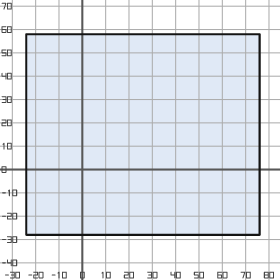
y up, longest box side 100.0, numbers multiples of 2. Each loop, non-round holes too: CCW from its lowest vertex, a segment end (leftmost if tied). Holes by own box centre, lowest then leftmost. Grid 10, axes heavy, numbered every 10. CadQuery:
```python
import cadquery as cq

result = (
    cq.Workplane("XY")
    .moveTo(-24.0, -28.0)
    .lineTo(76.0, -28.0)
    .lineTo(76.0, 58.0)
    .lineTo(-24.0, 58.0)
    .close()
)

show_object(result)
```